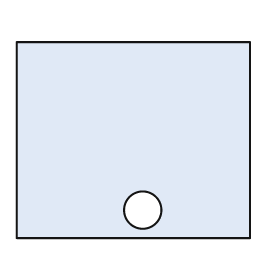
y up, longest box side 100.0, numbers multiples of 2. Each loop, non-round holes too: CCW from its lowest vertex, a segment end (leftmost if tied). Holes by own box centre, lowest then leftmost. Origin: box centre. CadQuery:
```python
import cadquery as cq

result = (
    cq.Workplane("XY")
    .moveTo(-50.0, -42.0)
    .lineTo(50.0, -42.0)
    .lineTo(50.0, 42.0)
    .lineTo(-50.0, 42.0)
    .close()
    .moveTo(4.0, -30.0)
    .circle(8.0)
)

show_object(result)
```